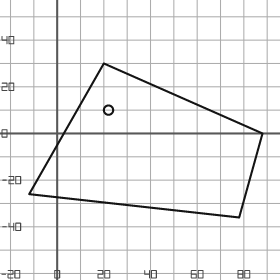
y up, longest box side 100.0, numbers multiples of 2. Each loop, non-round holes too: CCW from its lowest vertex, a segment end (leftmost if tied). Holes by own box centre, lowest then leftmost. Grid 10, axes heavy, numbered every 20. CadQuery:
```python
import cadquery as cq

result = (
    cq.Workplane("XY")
    .moveTo(78.0, -36.0)
    .lineTo(88.0, 0.0)
    .lineTo(20.0, 30.0)
    .lineTo(-12.0, -26.0)
    .close()
    .moveTo(22.0, 10.0)
    .circle(2.0)
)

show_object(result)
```